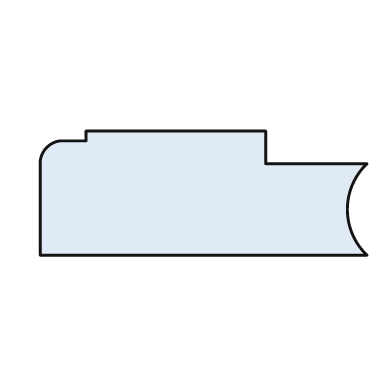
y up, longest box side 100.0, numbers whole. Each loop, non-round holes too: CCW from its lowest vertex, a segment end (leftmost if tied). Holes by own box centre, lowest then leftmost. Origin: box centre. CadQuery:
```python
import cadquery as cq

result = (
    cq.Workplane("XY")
    .moveTo(-50.0, -19.0)
    .lineTo(50.0, -19.0)
    .threePointArc((44.0, -5.0), (50.0, 9.0))
    .lineTo(19.0, 9.0)
    .lineTo(19.0, 19.0)
    .lineTo(-36.0, 19.0)
    .lineTo(-36.0, 16.0)
    .lineTo(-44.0, 16.0)
    .threePointArc((-48.0, 14.0), (-50.0, 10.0))
    .close()
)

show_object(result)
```